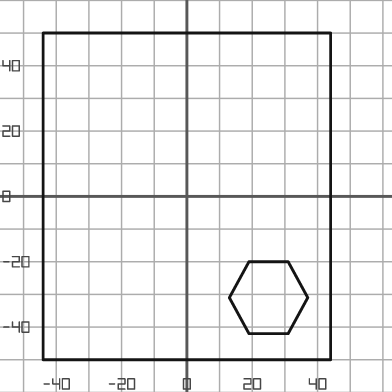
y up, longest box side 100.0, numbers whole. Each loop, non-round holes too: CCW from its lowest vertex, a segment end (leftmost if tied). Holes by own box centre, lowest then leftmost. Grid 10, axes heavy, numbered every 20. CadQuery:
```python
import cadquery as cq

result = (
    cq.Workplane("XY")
    .moveTo(-44.0, -50.0)
    .lineTo(44.0, -50.0)
    .lineTo(44.0, 50.0)
    .lineTo(-44.0, 50.0)
    .close()
    .moveTo(19.0, -42.0)
    .lineTo(31.0, -42.0)
    .lineTo(37.0, -31.0)
    .lineTo(31.0, -20.0)
    .lineTo(19.0, -20.0)
    .lineTo(13.0, -31.0)
    .close()
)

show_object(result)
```